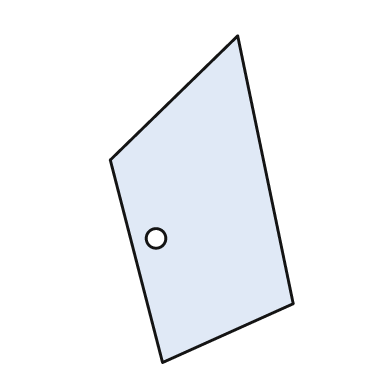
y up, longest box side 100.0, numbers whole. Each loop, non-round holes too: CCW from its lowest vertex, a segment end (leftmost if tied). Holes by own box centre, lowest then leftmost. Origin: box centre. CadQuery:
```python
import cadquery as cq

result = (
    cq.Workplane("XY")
    .moveTo(-12.0, -50.0)
    .lineTo(28.0, -32.0)
    .lineTo(11.0, 50.0)
    .lineTo(-28.0, 12.0)
    .close()
    .moveTo(-14.0, -12.0)
    .circle(3.0)
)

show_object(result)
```